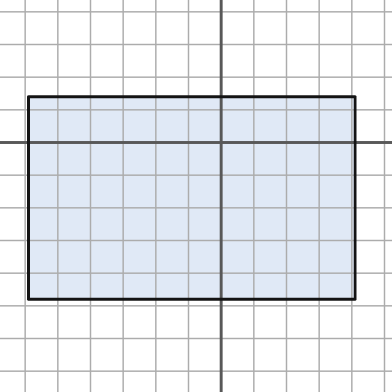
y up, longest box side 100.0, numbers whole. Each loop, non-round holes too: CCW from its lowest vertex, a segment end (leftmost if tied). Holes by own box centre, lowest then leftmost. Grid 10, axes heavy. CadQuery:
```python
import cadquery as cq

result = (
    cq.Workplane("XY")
    .moveTo(-59.0, -48.0)
    .lineTo(41.0, -48.0)
    .lineTo(41.0, 14.0)
    .lineTo(-59.0, 14.0)
    .close()
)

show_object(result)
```